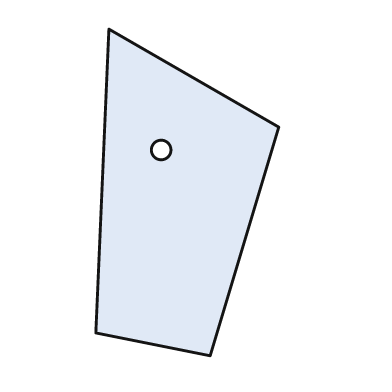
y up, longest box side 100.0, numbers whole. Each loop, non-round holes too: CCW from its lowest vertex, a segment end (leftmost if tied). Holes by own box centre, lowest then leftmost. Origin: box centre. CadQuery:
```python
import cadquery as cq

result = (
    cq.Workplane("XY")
    .moveTo(7.0, -50.0)
    .lineTo(28.0, 20.0)
    .lineTo(-24.0, 50.0)
    .lineTo(-28.0, -43.0)
    .close()
    .moveTo(-8.0, 13.0)
    .circle(3.0)
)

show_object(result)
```